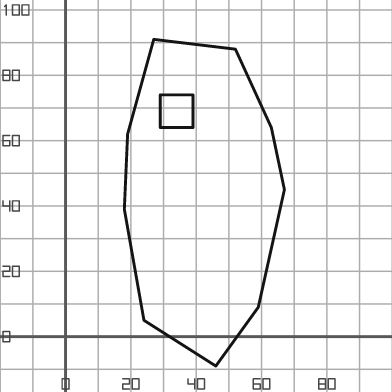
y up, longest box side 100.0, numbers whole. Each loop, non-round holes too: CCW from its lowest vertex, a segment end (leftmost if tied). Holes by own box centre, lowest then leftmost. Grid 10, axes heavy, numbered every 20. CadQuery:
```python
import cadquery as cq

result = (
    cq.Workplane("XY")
    .moveTo(46.0, -9.0)
    .lineTo(59.0, 9.0)
    .lineTo(67.0, 45.0)
    .lineTo(63.0, 64.0)
    .lineTo(52.0, 88.0)
    .lineTo(27.0, 91.0)
    .lineTo(19.0, 62.0)
    .lineTo(18.0, 39.0)
    .lineTo(24.0, 5.0)
    .close()
    .moveTo(29.0, 64.0)
    .lineTo(39.0, 64.0)
    .lineTo(39.0, 74.0)
    .lineTo(29.0, 74.0)
    .close()
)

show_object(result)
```